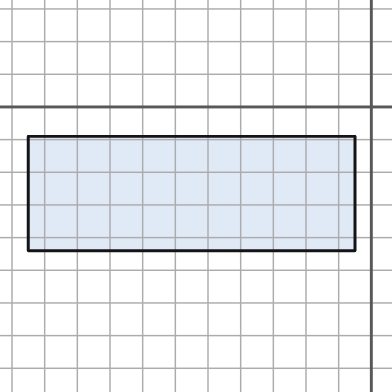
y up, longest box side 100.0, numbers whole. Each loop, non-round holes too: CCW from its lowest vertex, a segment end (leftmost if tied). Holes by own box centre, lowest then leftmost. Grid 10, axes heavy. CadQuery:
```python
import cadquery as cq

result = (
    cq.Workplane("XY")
    .moveTo(-105.0, -44.0)
    .lineTo(-5.0, -44.0)
    .lineTo(-5.0, -9.0)
    .lineTo(-105.0, -9.0)
    .close()
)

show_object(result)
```